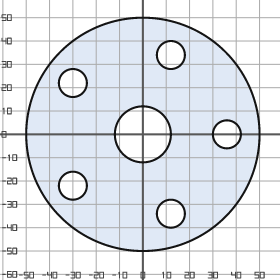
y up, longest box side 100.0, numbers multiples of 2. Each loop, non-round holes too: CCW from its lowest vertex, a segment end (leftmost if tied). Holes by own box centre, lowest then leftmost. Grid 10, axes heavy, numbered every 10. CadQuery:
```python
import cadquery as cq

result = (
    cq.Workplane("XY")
    .moveTo(0.0, 0.0)
    .circle(50.0)
    .moveTo(12.0, -34.0)
    .circle(6.0)
    .moveTo(-30.0, -22.0)
    .circle(6.0)
    .moveTo(0.0, 0.0)
    .circle(12.0)
    .moveTo(36.0, 0.0)
    .circle(6.0)
    .moveTo(-30.0, 22.0)
    .circle(6.0)
    .moveTo(12.0, 34.0)
    .circle(6.0)
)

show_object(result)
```